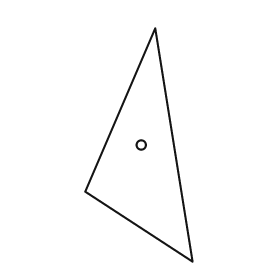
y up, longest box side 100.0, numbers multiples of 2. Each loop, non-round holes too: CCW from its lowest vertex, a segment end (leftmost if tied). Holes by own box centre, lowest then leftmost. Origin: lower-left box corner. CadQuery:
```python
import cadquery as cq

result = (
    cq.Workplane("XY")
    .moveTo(46.0, 0.0)
    .lineTo(30.0, 100.0)
    .lineTo(0.0, 30.0)
    .close()
    .moveTo(24.0, 50.0)
    .circle(2.0)
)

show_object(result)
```